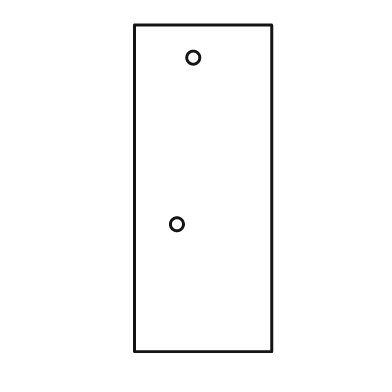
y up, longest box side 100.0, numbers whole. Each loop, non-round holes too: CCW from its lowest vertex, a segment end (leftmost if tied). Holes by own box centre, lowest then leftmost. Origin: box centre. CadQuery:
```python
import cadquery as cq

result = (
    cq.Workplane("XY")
    .moveTo(-21.0, -50.0)
    .lineTo(21.0, -50.0)
    .lineTo(21.0, 50.0)
    .lineTo(-21.0, 50.0)
    .close()
    .moveTo(-8.0, -11.0)
    .circle(2.0)
    .moveTo(-3.0, 40.0)
    .circle(2.0)
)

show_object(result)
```